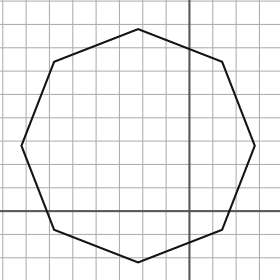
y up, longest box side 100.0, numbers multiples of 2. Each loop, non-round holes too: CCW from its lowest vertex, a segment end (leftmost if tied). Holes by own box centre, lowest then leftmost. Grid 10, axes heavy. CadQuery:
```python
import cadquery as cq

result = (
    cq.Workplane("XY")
    .moveTo(-22.0, -22.0)
    .lineTo(14.0, -8.0)
    .lineTo(28.0, 28.0)
    .lineTo(14.0, 64.0)
    .lineTo(-22.0, 78.0)
    .lineTo(-58.0, 64.0)
    .lineTo(-72.0, 28.0)
    .lineTo(-58.0, -8.0)
    .close()
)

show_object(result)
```